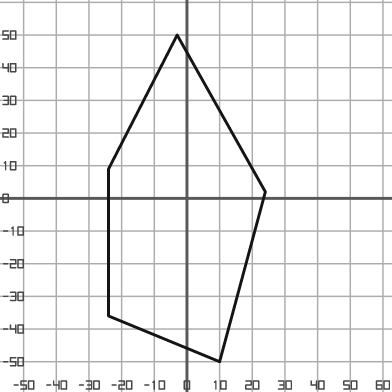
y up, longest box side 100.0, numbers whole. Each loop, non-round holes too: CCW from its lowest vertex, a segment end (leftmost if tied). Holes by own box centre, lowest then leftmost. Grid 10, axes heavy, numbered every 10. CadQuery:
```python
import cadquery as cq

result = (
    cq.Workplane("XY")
    .moveTo(10.0, -50.0)
    .lineTo(24.0, 2.0)
    .lineTo(-3.0, 50.0)
    .lineTo(-24.0, 9.0)
    .lineTo(-24.0, -36.0)
    .close()
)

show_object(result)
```